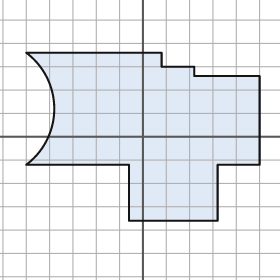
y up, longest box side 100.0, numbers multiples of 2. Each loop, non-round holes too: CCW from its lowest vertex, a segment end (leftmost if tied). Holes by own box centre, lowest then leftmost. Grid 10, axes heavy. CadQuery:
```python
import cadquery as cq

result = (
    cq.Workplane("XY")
    .moveTo(-6.0, -36.0)
    .lineTo(32.0, -36.0)
    .lineTo(32.0, -12.0)
    .lineTo(50.0, -12.0)
    .lineTo(50.0, 26.0)
    .lineTo(22.0, 26.0)
    .lineTo(22.0, 30.0)
    .lineTo(8.0, 30.0)
    .lineTo(8.0, 36.0)
    .lineTo(-50.0, 36.0)
    .threePointArc((-38.0, 12.0), (-50.0, -12.0))
    .lineTo(-6.0, -12.0)
    .close()
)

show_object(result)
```